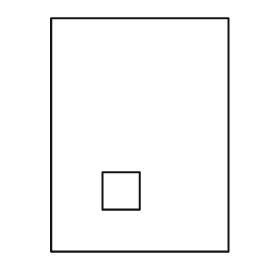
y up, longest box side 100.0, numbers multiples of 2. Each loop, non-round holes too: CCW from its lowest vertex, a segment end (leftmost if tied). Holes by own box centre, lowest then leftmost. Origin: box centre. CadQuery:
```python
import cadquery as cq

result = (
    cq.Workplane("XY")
    .moveTo(-38.0, -50.0)
    .lineTo(38.0, -50.0)
    .lineTo(38.0, 50.0)
    .lineTo(-38.0, 50.0)
    .close()
    .moveTo(-16.0, -32.0)
    .lineTo(0.0, -32.0)
    .lineTo(0.0, -16.0)
    .lineTo(-16.0, -16.0)
    .close()
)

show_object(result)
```